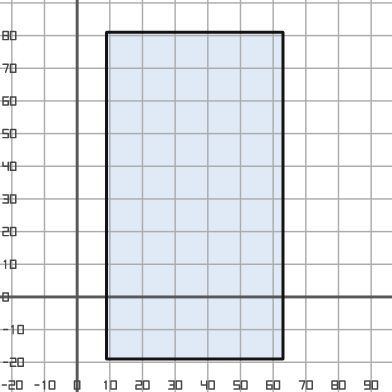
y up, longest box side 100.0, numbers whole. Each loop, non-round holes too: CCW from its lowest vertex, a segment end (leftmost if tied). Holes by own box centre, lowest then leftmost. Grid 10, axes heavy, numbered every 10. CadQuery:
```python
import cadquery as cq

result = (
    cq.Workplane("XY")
    .moveTo(9.0, -19.0)
    .lineTo(63.0, -19.0)
    .lineTo(63.0, 81.0)
    .lineTo(9.0, 81.0)
    .close()
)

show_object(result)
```